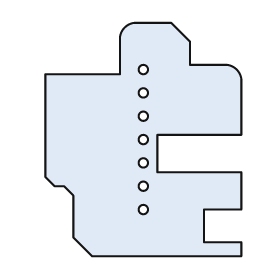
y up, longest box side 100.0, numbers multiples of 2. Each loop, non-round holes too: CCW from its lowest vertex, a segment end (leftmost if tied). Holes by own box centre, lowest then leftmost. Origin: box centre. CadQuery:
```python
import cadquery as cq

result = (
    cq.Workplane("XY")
    .moveTo(-22.0, -50.0)
    .lineTo(42.0, -50.0)
    .lineTo(42.0, -44.0)
    .lineTo(26.0, -44.0)
    .lineTo(26.0, -30.0)
    .lineTo(42.0, -30.0)
    .lineTo(42.0, -14.0)
    .lineTo(6.0, -14.0)
    .lineTo(6.0, 2.0)
    .lineTo(42.0, 2.0)
    .lineTo(42.0, 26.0)
    .threePointArc((40.0, 30.0), (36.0, 32.0))
    .lineTo(20.0, 32.0)
    .lineTo(20.0, 42.0)
    .lineTo(12.0, 50.0)
    .lineTo(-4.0, 50.0)
    .threePointArc((-8.0, 48.0), (-10.0, 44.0))
    .lineTo(-10.0, 28.0)
    .lineTo(-42.0, 28.0)
    .lineTo(-42.0, -16.0)
    .lineTo(-38.0, -20.0)
    .lineTo(-34.0, -20.0)
    .lineTo(-30.0, -24.0)
    .lineTo(-30.0, -42.0)
    .close()
    .moveTo(0.0, -30.0)
    .circle(2.0)
    .moveTo(0.0, -20.0)
    .circle(2.0)
    .moveTo(0.0, -10.0)
    .circle(2.0)
    .moveTo(0.0, 0.0)
    .circle(2.0)
    .moveTo(0.0, 10.0)
    .circle(2.0)
    .moveTo(0.0, 20.0)
    .circle(2.0)
    .moveTo(0.0, 30.0)
    .circle(2.0)
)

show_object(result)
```